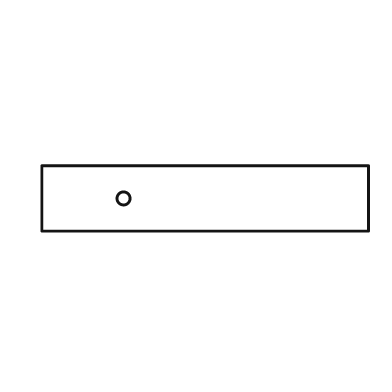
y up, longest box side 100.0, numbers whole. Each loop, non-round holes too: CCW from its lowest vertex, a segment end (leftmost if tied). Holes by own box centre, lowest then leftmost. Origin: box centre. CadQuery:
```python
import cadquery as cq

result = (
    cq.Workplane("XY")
    .moveTo(-50.0, -10.0)
    .lineTo(50.0, -10.0)
    .lineTo(50.0, 10.0)
    .lineTo(-50.0, 10.0)
    .close()
    .moveTo(-25.0, 0.0)
    .circle(2.0)
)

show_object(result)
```